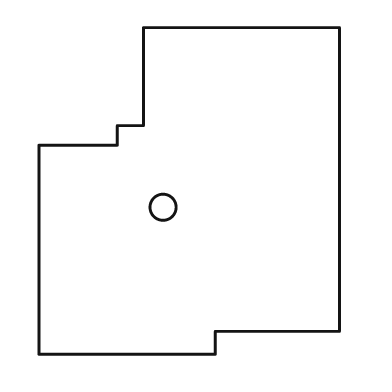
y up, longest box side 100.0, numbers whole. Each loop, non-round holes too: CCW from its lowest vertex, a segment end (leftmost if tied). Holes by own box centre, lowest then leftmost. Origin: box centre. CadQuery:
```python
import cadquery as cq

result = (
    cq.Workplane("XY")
    .moveTo(-46.0, -50.0)
    .lineTo(8.0, -50.0)
    .lineTo(8.0, -43.0)
    .lineTo(46.0, -43.0)
    .lineTo(46.0, 50.0)
    .lineTo(-14.0, 50.0)
    .lineTo(-14.0, 20.0)
    .lineTo(-22.0, 20.0)
    .lineTo(-22.0, 14.0)
    .lineTo(-46.0, 14.0)
    .close()
    .moveTo(-8.0, -5.0)
    .circle(4.0)
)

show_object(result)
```